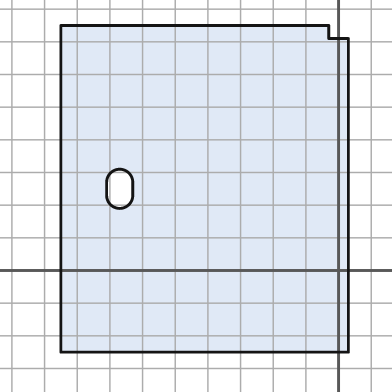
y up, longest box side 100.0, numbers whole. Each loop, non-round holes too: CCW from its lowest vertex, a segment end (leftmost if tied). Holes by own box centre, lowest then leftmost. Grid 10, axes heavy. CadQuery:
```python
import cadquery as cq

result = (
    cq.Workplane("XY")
    .moveTo(-85.0, -25.0)
    .lineTo(3.0, -25.0)
    .lineTo(3.0, 71.0)
    .lineTo(-3.0, 71.0)
    .lineTo(-3.0, 75.0)
    .lineTo(-85.0, 75.0)
    .close()
    .moveTo(-71.0, 23.0)
    .threePointArc((-67.0, 19.0), (-63.0, 23.0))
    .lineTo(-63.0, 27.0)
    .threePointArc((-67.0, 31.0), (-71.0, 27.0))
    .close()
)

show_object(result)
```